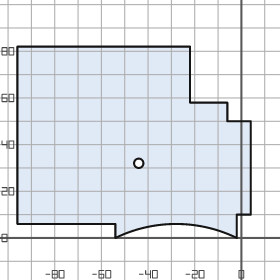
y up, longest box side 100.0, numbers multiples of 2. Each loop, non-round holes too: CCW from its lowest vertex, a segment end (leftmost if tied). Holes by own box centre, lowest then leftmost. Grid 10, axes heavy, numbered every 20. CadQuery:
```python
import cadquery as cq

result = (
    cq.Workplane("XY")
    .moveTo(-54.0, 0.0)
    .threePointArc((-28.0, 6.0), (-2.0, 0.0))
    .lineTo(-2.0, 10.0)
    .lineTo(4.0, 10.0)
    .lineTo(4.0, 50.0)
    .lineTo(-6.0, 50.0)
    .lineTo(-6.0, 58.0)
    .lineTo(-22.0, 58.0)
    .lineTo(-22.0, 82.0)
    .lineTo(-96.0, 82.0)
    .lineTo(-96.0, 6.0)
    .lineTo(-54.0, 6.0)
    .close()
    .moveTo(-44.0, 32.0)
    .circle(2.0)
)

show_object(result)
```